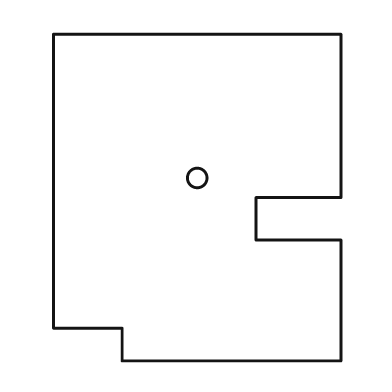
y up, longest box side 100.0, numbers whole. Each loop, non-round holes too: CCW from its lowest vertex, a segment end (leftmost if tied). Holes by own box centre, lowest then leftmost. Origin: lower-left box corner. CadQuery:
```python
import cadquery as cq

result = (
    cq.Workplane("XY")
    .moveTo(21.0, 0.0)
    .lineTo(88.0, 0.0)
    .lineTo(88.0, 37.0)
    .lineTo(62.0, 37.0)
    .lineTo(62.0, 50.0)
    .lineTo(88.0, 50.0)
    .lineTo(88.0, 100.0)
    .lineTo(0.0, 100.0)
    .lineTo(0.0, 10.0)
    .lineTo(21.0, 10.0)
    .close()
    .moveTo(44.0, 56.0)
    .circle(3.0)
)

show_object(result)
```